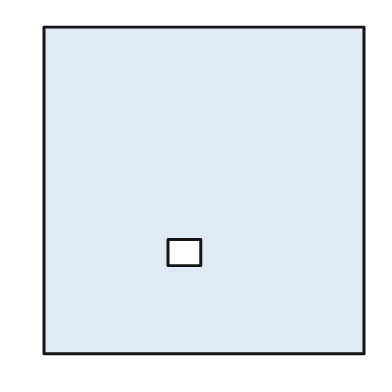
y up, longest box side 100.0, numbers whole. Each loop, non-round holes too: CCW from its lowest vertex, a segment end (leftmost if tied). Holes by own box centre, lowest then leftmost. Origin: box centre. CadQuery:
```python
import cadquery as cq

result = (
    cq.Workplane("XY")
    .moveTo(-49.0, -50.0)
    .lineTo(49.0, -50.0)
    .lineTo(49.0, 50.0)
    .lineTo(-49.0, 50.0)
    .close()
    .moveTo(-11.0, -23.0)
    .lineTo(-1.0, -23.0)
    .lineTo(-1.0, -15.0)
    .lineTo(-11.0, -15.0)
    .close()
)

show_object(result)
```